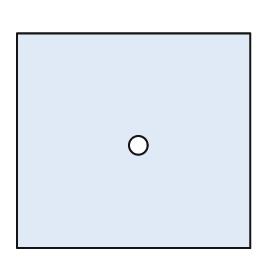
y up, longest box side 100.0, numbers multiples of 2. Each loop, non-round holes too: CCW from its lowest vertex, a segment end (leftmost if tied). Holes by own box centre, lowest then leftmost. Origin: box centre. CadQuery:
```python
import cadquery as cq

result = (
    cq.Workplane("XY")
    .moveTo(-50.0, -46.0)
    .lineTo(50.0, -46.0)
    .lineTo(50.0, 46.0)
    .lineTo(-50.0, 46.0)
    .close()
    .moveTo(2.0, -2.0)
    .circle(4.0)
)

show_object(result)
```